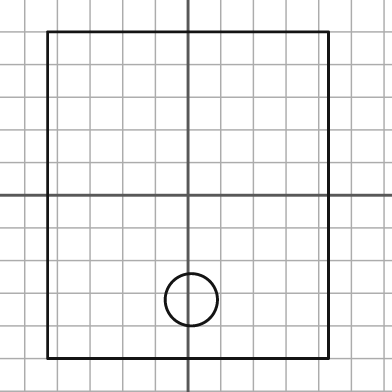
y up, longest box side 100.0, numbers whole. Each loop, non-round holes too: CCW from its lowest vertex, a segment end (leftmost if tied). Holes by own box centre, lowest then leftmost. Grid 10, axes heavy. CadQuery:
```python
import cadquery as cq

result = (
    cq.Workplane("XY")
    .moveTo(-43.0, -50.0)
    .lineTo(43.0, -50.0)
    .lineTo(43.0, 50.0)
    .lineTo(-43.0, 50.0)
    .close()
    .moveTo(1.0, -32.0)
    .circle(8.0)
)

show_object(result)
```